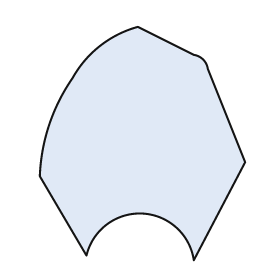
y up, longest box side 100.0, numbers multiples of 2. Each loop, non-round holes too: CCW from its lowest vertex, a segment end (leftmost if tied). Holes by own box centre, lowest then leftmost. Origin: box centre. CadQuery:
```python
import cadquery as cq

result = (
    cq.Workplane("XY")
    .moveTo(22.0, -50.0)
    .lineTo(44.0, -8.0)
    .lineTo(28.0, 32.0)
    .threePointArc((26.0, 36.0), (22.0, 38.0))
    .lineTo(-2.0, 50.0)
    .threePointArc((-18.0, 42.0), (-30.0, 28.0))
    .threePointArc((-40.0, 8.0), (-44.0, -14.0))
    .lineTo(-24.0, -48.0)
    .threePointArc((0.0, -30.0), (22.0, -50.0))
    .close()
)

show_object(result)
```